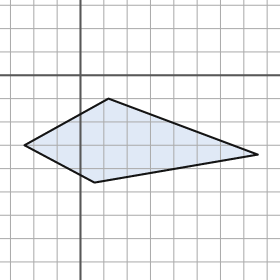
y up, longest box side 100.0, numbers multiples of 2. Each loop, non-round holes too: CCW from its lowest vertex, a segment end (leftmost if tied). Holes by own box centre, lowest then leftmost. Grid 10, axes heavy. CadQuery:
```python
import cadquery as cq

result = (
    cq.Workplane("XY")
    .moveTo(6.0, -46.0)
    .lineTo(76.0, -34.0)
    .lineTo(12.0, -10.0)
    .lineTo(-24.0, -30.0)
    .close()
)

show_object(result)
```